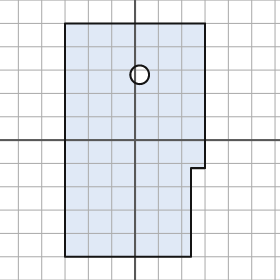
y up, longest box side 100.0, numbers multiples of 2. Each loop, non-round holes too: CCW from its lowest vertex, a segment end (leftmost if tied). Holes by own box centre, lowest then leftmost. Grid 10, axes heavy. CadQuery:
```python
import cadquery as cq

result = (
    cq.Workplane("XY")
    .moveTo(-30.0, -50.0)
    .lineTo(24.0, -50.0)
    .lineTo(24.0, -12.0)
    .lineTo(30.0, -12.0)
    .lineTo(30.0, 50.0)
    .lineTo(-30.0, 50.0)
    .close()
    .moveTo(2.0, 28.0)
    .circle(4.0)
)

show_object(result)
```